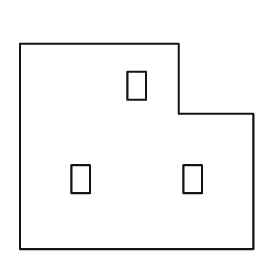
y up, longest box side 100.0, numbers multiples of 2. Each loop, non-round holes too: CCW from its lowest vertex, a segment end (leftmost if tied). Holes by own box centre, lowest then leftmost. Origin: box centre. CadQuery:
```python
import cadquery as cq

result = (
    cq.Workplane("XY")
    .moveTo(-50.0, -44.0)
    .lineTo(50.0, -44.0)
    .lineTo(50.0, 14.0)
    .lineTo(18.0, 14.0)
    .lineTo(18.0, 44.0)
    .lineTo(-50.0, 44.0)
    .close()
    .moveTo(-28.0, -20.0)
    .lineTo(-20.0, -20.0)
    .lineTo(-20.0, -8.0)
    .lineTo(-28.0, -8.0)
    .close()
    .moveTo(20.0, -20.0)
    .lineTo(28.0, -20.0)
    .lineTo(28.0, -8.0)
    .lineTo(20.0, -8.0)
    .close()
    .moveTo(-4.0, 20.0)
    .lineTo(4.0, 20.0)
    .lineTo(4.0, 32.0)
    .lineTo(-4.0, 32.0)
    .close()
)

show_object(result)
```